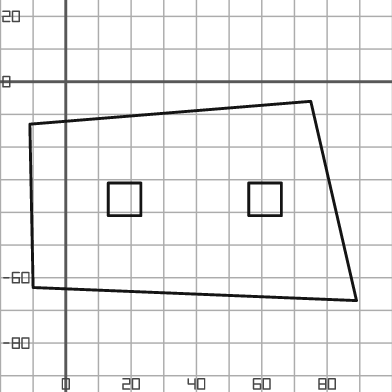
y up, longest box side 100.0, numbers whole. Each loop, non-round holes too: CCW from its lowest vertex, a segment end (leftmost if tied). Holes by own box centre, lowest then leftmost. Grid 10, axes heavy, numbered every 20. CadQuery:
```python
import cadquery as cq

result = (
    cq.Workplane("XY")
    .moveTo(89.0, -67.0)
    .lineTo(75.0, -6.0)
    .lineTo(-11.0, -13.0)
    .lineTo(-10.0, -63.0)
    .close()
    .moveTo(13.0, -41.0)
    .lineTo(23.0, -41.0)
    .lineTo(23.0, -31.0)
    .lineTo(13.0, -31.0)
    .close()
    .moveTo(56.0, -41.0)
    .lineTo(66.0, -41.0)
    .lineTo(66.0, -31.0)
    .lineTo(56.0, -31.0)
    .close()
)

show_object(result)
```